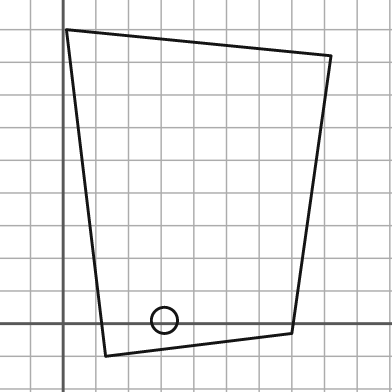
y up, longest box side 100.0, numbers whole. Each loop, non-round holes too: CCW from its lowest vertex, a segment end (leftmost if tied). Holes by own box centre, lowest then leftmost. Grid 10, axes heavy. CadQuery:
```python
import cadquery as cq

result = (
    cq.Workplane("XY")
    .moveTo(13.0, -10.0)
    .lineTo(70.0, -3.0)
    .lineTo(82.0, 82.0)
    .lineTo(1.0, 90.0)
    .close()
    .moveTo(31.0, 1.0)
    .circle(4.0)
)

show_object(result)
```